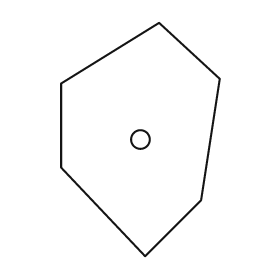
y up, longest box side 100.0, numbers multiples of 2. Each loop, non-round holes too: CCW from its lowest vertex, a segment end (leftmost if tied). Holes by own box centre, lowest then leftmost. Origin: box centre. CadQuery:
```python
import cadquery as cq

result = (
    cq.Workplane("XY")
    .moveTo(2.0, -50.0)
    .lineTo(26.0, -26.0)
    .lineTo(34.0, 26.0)
    .lineTo(8.0, 50.0)
    .lineTo(-34.0, 24.0)
    .lineTo(-34.0, -12.0)
    .close()
    .moveTo(0.0, 0.0)
    .circle(4.0)
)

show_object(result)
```